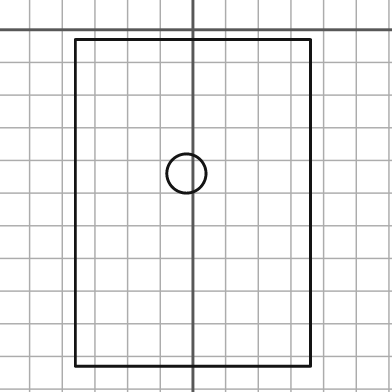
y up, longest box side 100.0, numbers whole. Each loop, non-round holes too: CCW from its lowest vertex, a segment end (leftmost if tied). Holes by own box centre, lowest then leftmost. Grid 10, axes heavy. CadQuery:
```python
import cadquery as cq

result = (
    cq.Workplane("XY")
    .moveTo(-36.0, -103.0)
    .lineTo(36.0, -103.0)
    .lineTo(36.0, -3.0)
    .lineTo(-36.0, -3.0)
    .close()
    .moveTo(-2.0, -44.0)
    .circle(6.0)
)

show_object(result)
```